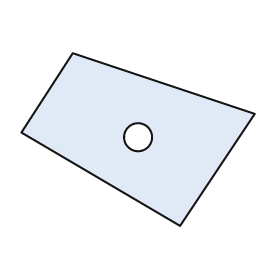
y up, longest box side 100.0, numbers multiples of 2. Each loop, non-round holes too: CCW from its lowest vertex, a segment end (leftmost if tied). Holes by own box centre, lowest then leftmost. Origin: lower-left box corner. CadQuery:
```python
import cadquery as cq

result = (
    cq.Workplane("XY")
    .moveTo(68.0, 0.0)
    .lineTo(100.0, 48.0)
    .lineTo(22.0, 74.0)
    .lineTo(0.0, 40.0)
    .close()
    .moveTo(50.0, 38.0)
    .circle(6.0)
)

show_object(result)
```